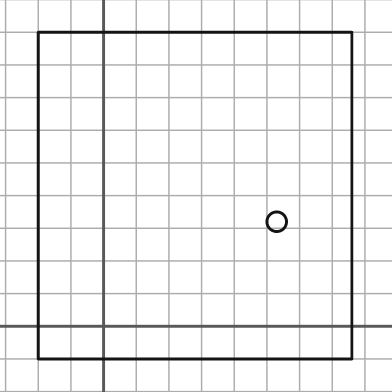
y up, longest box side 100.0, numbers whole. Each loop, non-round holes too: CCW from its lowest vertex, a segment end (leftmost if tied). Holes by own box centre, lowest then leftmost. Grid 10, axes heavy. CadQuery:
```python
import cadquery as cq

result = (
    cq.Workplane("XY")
    .moveTo(-20.0, -10.0)
    .lineTo(76.0, -10.0)
    .lineTo(76.0, 90.0)
    .lineTo(-20.0, 90.0)
    .close()
    .moveTo(53.0, 32.0)
    .circle(3.0)
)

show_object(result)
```